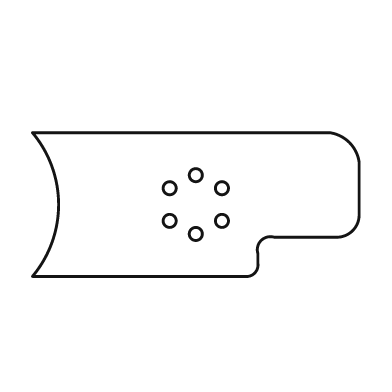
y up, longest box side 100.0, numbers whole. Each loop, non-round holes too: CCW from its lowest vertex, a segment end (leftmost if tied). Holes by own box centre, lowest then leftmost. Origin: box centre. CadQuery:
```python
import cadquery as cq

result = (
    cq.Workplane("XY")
    .moveTo(-50.0, -22.0)
    .lineTo(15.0, -22.0)
    .threePointArc((18.0, -21.0), (19.0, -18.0))
    .lineTo(19.0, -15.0)
    .threePointArc((20.0, -11.0), (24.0, -10.0))
    .lineTo(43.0, -10.0)
    .threePointArc((48.0, -8.0), (50.0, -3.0))
    .lineTo(50.0, 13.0)
    .threePointArc((47.0, 19.0), (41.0, 22.0))
    .lineTo(-50.0, 22.0)
    .threePointArc((-42.0, 0.0), (-50.0, -22.0))
    .close()
    .moveTo(0.0, -9.0)
    .circle(2.0)
    .moveTo(-8.0, -5.0)
    .circle(2.0)
    .moveTo(8.0, -5.0)
    .circle(2.0)
    .moveTo(-8.0, 5.0)
    .circle(2.0)
    .moveTo(8.0, 5.0)
    .circle(2.0)
    .moveTo(0.0, 9.0)
    .circle(2.0)
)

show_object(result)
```